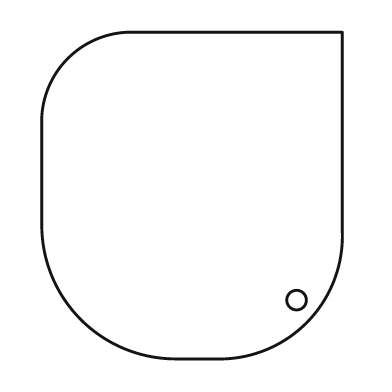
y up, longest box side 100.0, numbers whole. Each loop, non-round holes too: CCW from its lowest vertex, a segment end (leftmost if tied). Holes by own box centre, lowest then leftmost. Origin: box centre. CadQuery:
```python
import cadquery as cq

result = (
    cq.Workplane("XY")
    .moveTo(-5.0, -50.0)
    .lineTo(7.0, -50.0)
    .threePointArc((35.0, -39.0), (46.0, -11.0))
    .lineTo(46.0, 50.0)
    .lineTo(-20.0, 50.0)
    .threePointArc((-38.0, 42.0), (-46.0, 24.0))
    .lineTo(-46.0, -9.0)
    .threePointArc((-34.0, -38.0), (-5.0, -50.0))
    .close()
    .moveTo(32.0, -32.0)
    .circle(3.0)
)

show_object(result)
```